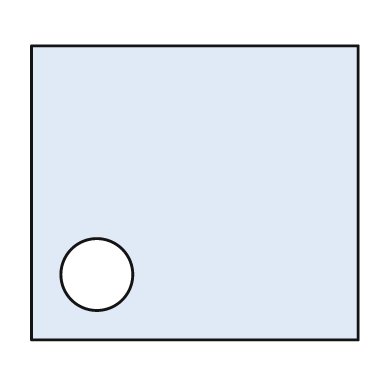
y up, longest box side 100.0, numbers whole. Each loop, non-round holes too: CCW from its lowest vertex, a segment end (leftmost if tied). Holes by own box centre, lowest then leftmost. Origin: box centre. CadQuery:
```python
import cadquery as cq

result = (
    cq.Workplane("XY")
    .moveTo(-50.0, -45.0)
    .lineTo(50.0, -45.0)
    .lineTo(50.0, 45.0)
    .lineTo(-50.0, 45.0)
    .close()
    .moveTo(-30.0, -25.0)
    .circle(11.0)
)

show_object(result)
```